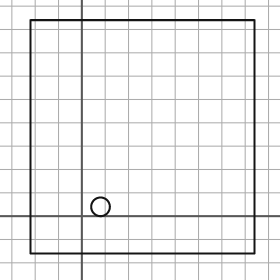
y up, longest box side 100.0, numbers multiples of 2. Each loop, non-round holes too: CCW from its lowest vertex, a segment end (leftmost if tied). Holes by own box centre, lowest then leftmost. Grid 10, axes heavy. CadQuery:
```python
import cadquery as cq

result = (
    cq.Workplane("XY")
    .moveTo(-22.0, -16.0)
    .lineTo(74.0, -16.0)
    .lineTo(74.0, 84.0)
    .lineTo(-22.0, 84.0)
    .close()
    .moveTo(8.0, 4.0)
    .circle(4.0)
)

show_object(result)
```